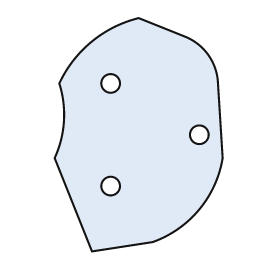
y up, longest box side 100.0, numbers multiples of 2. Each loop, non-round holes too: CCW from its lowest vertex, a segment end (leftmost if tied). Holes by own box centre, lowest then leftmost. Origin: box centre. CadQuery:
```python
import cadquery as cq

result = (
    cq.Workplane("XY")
    .moveTo(-20.0, -50.0)
    .lineTo(6.0, -46.0)
    .threePointArc((26.0, -32.0), (36.0, -10.0))
    .lineTo(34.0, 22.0)
    .threePointArc((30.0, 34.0), (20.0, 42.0))
    .lineTo(0.0, 50.0)
    .threePointArc((-20.0, 40.0), (-34.0, 22.0))
    .threePointArc((-32.0, 6.0), (-36.0, -10.0))
    .close()
    .moveTo(-12.0, -22.0)
    .circle(4.0)
    .moveTo(26.0, 0.0)
    .circle(4.0)
    .moveTo(-12.0, 22.0)
    .circle(4.0)
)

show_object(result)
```